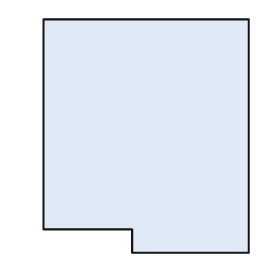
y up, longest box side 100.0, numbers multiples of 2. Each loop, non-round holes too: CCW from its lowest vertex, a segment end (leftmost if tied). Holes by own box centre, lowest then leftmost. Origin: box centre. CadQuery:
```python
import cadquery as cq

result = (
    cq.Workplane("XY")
    .moveTo(-6.0, -50.0)
    .lineTo(44.0, -50.0)
    .lineTo(44.0, 50.0)
    .lineTo(-44.0, 50.0)
    .lineTo(-44.0, -40.0)
    .lineTo(-6.0, -40.0)
    .close()
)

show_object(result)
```